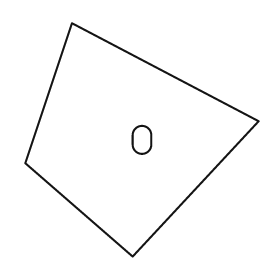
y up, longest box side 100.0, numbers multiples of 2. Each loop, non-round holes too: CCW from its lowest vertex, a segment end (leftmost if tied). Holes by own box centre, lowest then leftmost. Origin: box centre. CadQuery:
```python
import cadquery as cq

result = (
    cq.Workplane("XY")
    .moveTo(-4.0, -50.0)
    .lineTo(50.0, 8.0)
    .lineTo(-30.0, 50.0)
    .lineTo(-50.0, -10.0)
    .close()
    .moveTo(-4.0, -2.0)
    .threePointArc((0.0, -6.0), (4.0, -2.0))
    .lineTo(4.0, 2.0)
    .threePointArc((0.0, 6.0), (-4.0, 2.0))
    .close()
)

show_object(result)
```